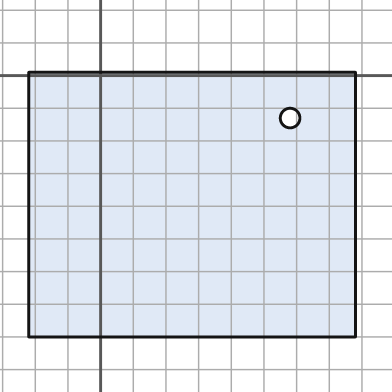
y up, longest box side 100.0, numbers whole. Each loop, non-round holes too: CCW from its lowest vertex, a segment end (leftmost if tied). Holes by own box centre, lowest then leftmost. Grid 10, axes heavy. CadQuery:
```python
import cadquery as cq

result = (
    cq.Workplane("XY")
    .moveTo(-22.0, -80.0)
    .lineTo(78.0, -80.0)
    .lineTo(78.0, 1.0)
    .lineTo(-22.0, 1.0)
    .close()
    .moveTo(58.0, -13.0)
    .circle(3.0)
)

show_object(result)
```